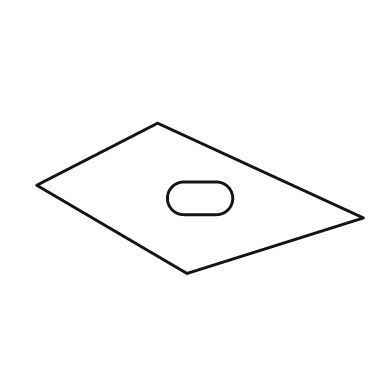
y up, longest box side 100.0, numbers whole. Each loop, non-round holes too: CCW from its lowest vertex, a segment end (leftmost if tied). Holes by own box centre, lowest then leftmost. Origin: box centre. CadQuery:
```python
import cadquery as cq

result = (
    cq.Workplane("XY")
    .moveTo(-4.0, -23.0)
    .lineTo(50.0, -6.0)
    .lineTo(-13.0, 23.0)
    .lineTo(-50.0, 4.0)
    .close()
    .moveTo(-5.0, -5.0)
    .lineTo(5.0, -5.0)
    .threePointArc((10.0, 0.0), (5.0, 5.0))
    .lineTo(-5.0, 5.0)
    .threePointArc((-10.0, 0.0), (-5.0, -5.0))
    .close()
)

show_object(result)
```